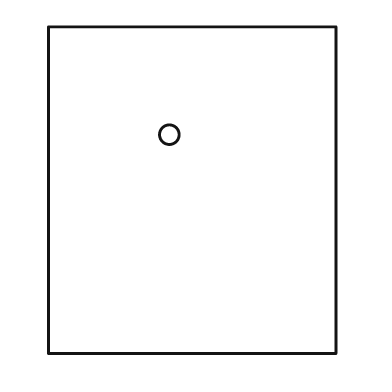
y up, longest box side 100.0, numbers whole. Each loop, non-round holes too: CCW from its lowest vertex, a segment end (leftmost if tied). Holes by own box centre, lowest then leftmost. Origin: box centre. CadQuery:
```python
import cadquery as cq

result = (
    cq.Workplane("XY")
    .moveTo(-44.0, -50.0)
    .lineTo(44.0, -50.0)
    .lineTo(44.0, 50.0)
    .lineTo(-44.0, 50.0)
    .close()
    .moveTo(-7.0, 17.0)
    .circle(3.0)
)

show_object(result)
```